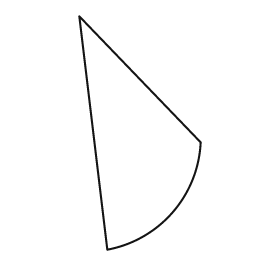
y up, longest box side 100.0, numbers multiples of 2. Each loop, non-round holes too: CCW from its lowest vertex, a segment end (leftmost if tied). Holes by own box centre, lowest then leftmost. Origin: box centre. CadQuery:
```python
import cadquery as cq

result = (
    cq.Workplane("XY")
    .moveTo(-14.0, -50.0)
    .threePointArc((14.0, -34.0), (26.0, -4.0))
    .lineTo(-26.0, 50.0)
    .close()
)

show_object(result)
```